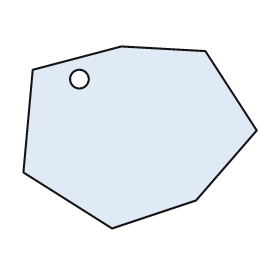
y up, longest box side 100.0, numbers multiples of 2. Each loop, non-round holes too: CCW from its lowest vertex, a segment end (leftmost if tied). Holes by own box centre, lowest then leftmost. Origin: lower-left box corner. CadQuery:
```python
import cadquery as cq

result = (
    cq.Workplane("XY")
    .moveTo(38.0, 0.0)
    .lineTo(74.0, 12.0)
    .lineTo(100.0, 42.0)
    .lineTo(78.0, 76.0)
    .lineTo(42.0, 78.0)
    .lineTo(4.0, 68.0)
    .lineTo(0.0, 24.0)
    .close()
    .moveTo(24.0, 64.0)
    .circle(4.0)
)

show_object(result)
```